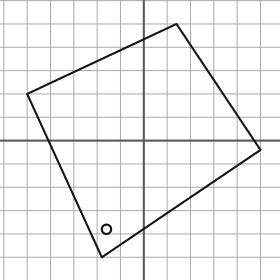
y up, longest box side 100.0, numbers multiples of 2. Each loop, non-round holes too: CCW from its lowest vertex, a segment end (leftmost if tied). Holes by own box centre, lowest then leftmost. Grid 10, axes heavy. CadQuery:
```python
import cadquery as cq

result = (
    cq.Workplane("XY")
    .moveTo(-18.0, -50.0)
    .lineTo(50.0, -4.0)
    .lineTo(14.0, 50.0)
    .lineTo(-50.0, 20.0)
    .close()
    .moveTo(-16.0, -38.0)
    .circle(2.0)
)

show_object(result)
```